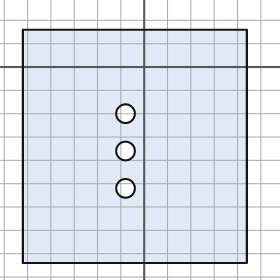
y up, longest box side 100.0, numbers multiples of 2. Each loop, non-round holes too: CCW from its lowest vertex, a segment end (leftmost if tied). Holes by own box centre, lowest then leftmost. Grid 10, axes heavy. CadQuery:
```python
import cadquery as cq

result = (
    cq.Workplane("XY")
    .moveTo(-52.0, -84.0)
    .lineTo(44.0, -84.0)
    .lineTo(44.0, 16.0)
    .lineTo(-52.0, 16.0)
    .close()
    .moveTo(-8.0, -52.0)
    .circle(4.0)
    .moveTo(-8.0, -36.0)
    .circle(4.0)
    .moveTo(-8.0, -20.0)
    .circle(4.0)
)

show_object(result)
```